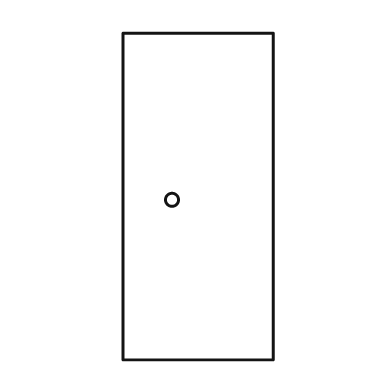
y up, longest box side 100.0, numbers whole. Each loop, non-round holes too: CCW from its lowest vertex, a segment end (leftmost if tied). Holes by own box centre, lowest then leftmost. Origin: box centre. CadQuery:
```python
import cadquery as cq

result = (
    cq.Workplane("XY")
    .moveTo(-23.0, -50.0)
    .lineTo(23.0, -50.0)
    .lineTo(23.0, 50.0)
    .lineTo(-23.0, 50.0)
    .close()
    .moveTo(-8.0, -1.0)
    .circle(2.0)
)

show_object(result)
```